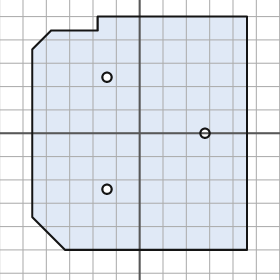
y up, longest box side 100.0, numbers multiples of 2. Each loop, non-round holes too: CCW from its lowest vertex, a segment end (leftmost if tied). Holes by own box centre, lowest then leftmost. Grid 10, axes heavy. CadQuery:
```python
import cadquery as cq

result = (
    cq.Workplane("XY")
    .moveTo(-32.0, -50.0)
    .lineTo(46.0, -50.0)
    .lineTo(46.0, 50.0)
    .lineTo(-18.0, 50.0)
    .lineTo(-18.0, 44.0)
    .lineTo(-38.0, 44.0)
    .lineTo(-46.0, 36.0)
    .lineTo(-46.0, -36.0)
    .close()
    .moveTo(-14.0, -24.0)
    .circle(2.0)
    .moveTo(28.0, 0.0)
    .circle(2.0)
    .moveTo(-14.0, 24.0)
    .circle(2.0)
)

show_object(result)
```